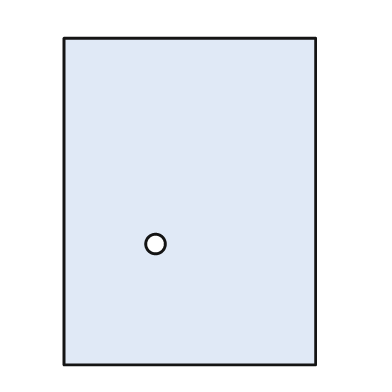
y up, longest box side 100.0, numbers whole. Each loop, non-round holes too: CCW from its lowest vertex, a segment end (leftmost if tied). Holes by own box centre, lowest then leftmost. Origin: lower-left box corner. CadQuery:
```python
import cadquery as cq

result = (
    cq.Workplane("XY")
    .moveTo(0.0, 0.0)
    .lineTo(77.0, 0.0)
    .lineTo(77.0, 100.0)
    .lineTo(0.0, 100.0)
    .close()
    .moveTo(28.0, 37.0)
    .circle(3.0)
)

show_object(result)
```